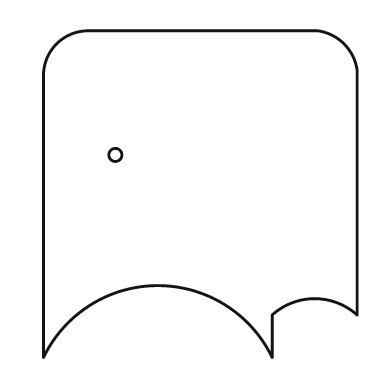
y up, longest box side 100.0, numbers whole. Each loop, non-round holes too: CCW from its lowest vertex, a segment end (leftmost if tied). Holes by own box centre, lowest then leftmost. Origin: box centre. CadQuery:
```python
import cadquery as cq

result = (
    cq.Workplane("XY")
    .moveTo(-48.0, -50.0)
    .threePointArc((-13.0, -28.0), (22.0, -50.0))
    .lineTo(22.0, -37.0)
    .threePointArc((35.0, -32.0), (48.0, -37.0))
    .lineTo(48.0, 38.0)
    .threePointArc((44.0, 46.0), (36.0, 50.0))
    .lineTo(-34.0, 50.0)
    .threePointArc((-44.0, 46.0), (-48.0, 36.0))
    .close()
    .moveTo(-26.0, 12.0)
    .circle(2.0)
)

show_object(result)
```